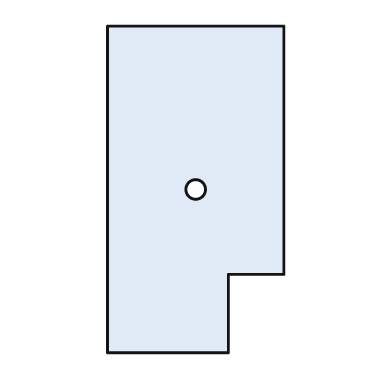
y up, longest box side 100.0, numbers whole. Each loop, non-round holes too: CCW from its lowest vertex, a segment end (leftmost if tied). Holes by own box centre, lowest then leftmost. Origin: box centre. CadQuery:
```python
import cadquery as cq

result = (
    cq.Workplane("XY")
    .moveTo(-27.0, -50.0)
    .lineTo(10.0, -50.0)
    .lineTo(10.0, -26.0)
    .lineTo(27.0, -26.0)
    .lineTo(27.0, 50.0)
    .lineTo(-27.0, 50.0)
    .close()
    .moveTo(0.0, 0.0)
    .circle(3.0)
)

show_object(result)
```